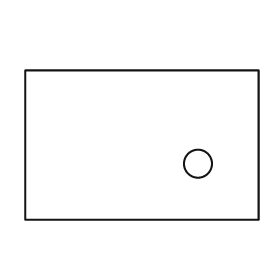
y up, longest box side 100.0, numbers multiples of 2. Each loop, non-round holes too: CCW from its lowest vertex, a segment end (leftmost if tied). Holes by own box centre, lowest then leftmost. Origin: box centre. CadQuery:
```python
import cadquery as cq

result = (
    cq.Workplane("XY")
    .moveTo(-50.0, -32.0)
    .lineTo(50.0, -32.0)
    .lineTo(50.0, 32.0)
    .lineTo(-50.0, 32.0)
    .close()
    .moveTo(24.0, -8.0)
    .circle(6.0)
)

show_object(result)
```